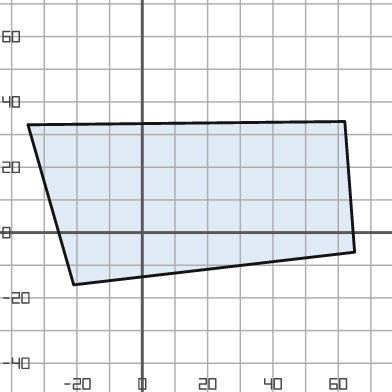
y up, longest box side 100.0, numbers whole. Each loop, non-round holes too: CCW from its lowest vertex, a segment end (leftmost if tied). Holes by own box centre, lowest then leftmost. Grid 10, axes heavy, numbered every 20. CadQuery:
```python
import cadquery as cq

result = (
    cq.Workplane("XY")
    .moveTo(-21.0, -16.0)
    .lineTo(65.0, -6.0)
    .lineTo(62.0, 34.0)
    .lineTo(-35.0, 33.0)
    .close()
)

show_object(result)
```